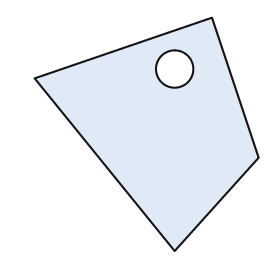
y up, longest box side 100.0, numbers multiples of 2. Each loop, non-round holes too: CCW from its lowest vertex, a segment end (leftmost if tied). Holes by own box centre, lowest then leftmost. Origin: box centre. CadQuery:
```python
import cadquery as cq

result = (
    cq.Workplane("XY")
    .moveTo(12.0, -50.0)
    .lineTo(48.0, -10.0)
    .lineTo(28.0, 50.0)
    .lineTo(-48.0, 24.0)
    .close()
    .moveTo(12.0, 28.0)
    .circle(8.0)
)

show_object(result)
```